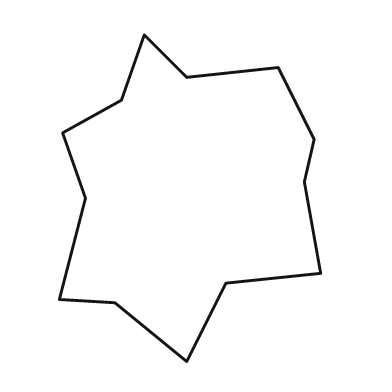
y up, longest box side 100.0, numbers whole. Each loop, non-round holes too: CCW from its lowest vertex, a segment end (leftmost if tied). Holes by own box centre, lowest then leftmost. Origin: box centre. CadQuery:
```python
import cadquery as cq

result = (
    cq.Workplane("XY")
    .moveTo(-1.0, -50.0)
    .lineTo(11.0, -26.0)
    .lineTo(40.0, -23.0)
    .lineTo(35.0, 5.0)
    .lineTo(38.0, 18.0)
    .lineTo(27.0, 40.0)
    .lineTo(-1.0, 37.0)
    .lineTo(-14.0, 50.0)
    .lineTo(-21.0, 30.0)
    .lineTo(-39.0, 20.0)
    .lineTo(-32.0, 0.0)
    .lineTo(-40.0, -31.0)
    .lineTo(-23.0, -32.0)
    .close()
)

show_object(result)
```